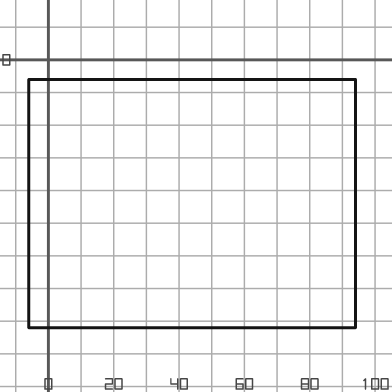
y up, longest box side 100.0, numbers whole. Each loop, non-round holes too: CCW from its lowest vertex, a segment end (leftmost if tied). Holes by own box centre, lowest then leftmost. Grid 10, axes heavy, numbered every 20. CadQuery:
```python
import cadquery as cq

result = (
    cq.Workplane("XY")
    .moveTo(-6.0, -82.0)
    .lineTo(94.0, -82.0)
    .lineTo(94.0, -6.0)
    .lineTo(-6.0, -6.0)
    .close()
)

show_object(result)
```